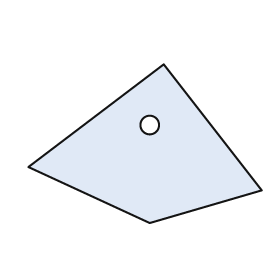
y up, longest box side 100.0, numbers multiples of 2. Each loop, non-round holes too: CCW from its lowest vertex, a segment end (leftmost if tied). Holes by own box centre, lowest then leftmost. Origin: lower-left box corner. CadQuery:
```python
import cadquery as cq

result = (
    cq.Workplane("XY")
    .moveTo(52.0, 0.0)
    .lineTo(100.0, 14.0)
    .lineTo(58.0, 68.0)
    .lineTo(0.0, 24.0)
    .close()
    .moveTo(52.0, 42.0)
    .circle(4.0)
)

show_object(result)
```